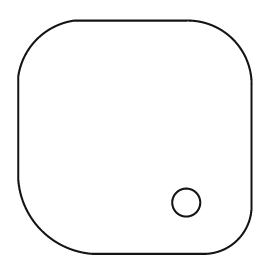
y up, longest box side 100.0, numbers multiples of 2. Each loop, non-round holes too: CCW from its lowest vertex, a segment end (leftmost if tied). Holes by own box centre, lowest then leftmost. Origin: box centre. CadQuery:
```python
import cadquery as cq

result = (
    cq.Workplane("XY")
    .moveTo(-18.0, -50.0)
    .lineTo(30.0, -50.0)
    .threePointArc((44.0, -44.0), (50.0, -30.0))
    .lineTo(50.0, 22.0)
    .threePointArc((42.0, 42.0), (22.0, 50.0))
    .lineTo(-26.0, 50.0)
    .threePointArc((-42.0, 42.0), (-50.0, 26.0))
    .lineTo(-50.0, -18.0)
    .threePointArc((-40.0, -40.0), (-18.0, -50.0))
    .close()
    .moveTo(22.0, -28.0)
    .circle(6.0)
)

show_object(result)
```